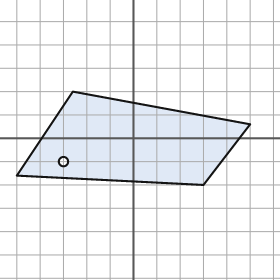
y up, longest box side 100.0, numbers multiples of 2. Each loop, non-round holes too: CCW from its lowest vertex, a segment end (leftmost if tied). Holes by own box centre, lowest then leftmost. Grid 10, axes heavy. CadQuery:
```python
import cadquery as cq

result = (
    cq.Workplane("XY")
    .moveTo(30.0, -20.0)
    .lineTo(50.0, 6.0)
    .lineTo(-26.0, 20.0)
    .lineTo(-50.0, -16.0)
    .close()
    .moveTo(-30.0, -10.0)
    .circle(2.0)
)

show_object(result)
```